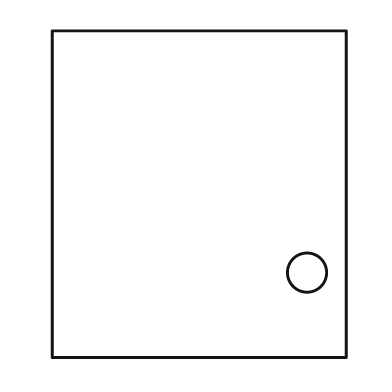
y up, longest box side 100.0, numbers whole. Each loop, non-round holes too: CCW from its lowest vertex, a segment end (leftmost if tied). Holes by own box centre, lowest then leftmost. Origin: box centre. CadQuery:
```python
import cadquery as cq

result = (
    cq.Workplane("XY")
    .moveTo(-45.0, -50.0)
    .lineTo(45.0, -50.0)
    .lineTo(45.0, 50.0)
    .lineTo(-45.0, 50.0)
    .close()
    .moveTo(33.0, -24.0)
    .circle(6.0)
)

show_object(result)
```